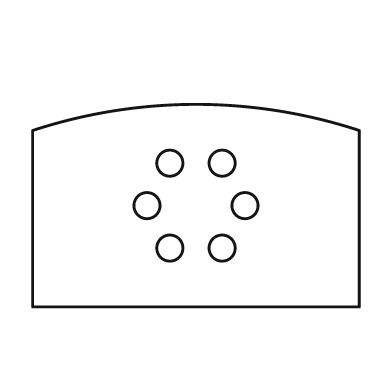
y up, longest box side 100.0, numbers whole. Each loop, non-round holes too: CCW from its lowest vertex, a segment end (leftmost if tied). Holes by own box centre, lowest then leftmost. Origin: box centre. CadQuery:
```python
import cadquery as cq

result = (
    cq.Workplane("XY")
    .moveTo(-50.0, -31.0)
    .lineTo(50.0, -31.0)
    .lineTo(50.0, 23.0)
    .threePointArc((0.0, 31.0), (-50.0, 23.0))
    .close()
    .moveTo(-8.0, -13.0)
    .circle(4.0)
    .moveTo(8.0, -13.0)
    .circle(4.0)
    .moveTo(-15.0, 0.0)
    .circle(4.0)
    .moveTo(15.0, 0.0)
    .circle(4.0)
    .moveTo(-8.0, 13.0)
    .circle(4.0)
    .moveTo(8.0, 13.0)
    .circle(4.0)
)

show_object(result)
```